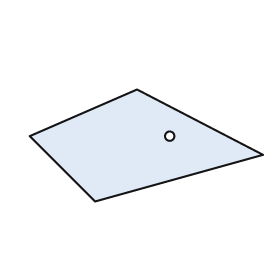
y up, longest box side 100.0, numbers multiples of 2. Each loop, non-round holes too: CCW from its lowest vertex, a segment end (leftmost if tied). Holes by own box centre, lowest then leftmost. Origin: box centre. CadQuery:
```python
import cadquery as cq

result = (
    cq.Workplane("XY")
    .moveTo(-22.0, -24.0)
    .lineTo(50.0, -4.0)
    .lineTo(-4.0, 24.0)
    .lineTo(-50.0, 4.0)
    .close()
    .moveTo(10.0, 4.0)
    .circle(2.0)
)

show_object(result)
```